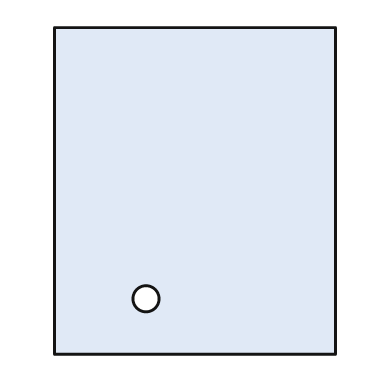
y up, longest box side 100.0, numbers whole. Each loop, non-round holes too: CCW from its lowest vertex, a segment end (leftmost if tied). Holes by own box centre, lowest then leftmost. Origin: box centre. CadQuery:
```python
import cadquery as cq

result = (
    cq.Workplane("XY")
    .moveTo(-43.0, -50.0)
    .lineTo(43.0, -50.0)
    .lineTo(43.0, 50.0)
    .lineTo(-43.0, 50.0)
    .close()
    .moveTo(-15.0, -33.0)
    .circle(4.0)
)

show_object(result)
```